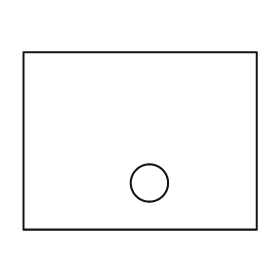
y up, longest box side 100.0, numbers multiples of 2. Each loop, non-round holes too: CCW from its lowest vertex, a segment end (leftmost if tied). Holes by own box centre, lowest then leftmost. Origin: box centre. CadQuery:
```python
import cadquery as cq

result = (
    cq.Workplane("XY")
    .moveTo(-50.0, -38.0)
    .lineTo(50.0, -38.0)
    .lineTo(50.0, 38.0)
    .lineTo(-50.0, 38.0)
    .close()
    .moveTo(4.0, -18.0)
    .circle(8.0)
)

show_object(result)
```